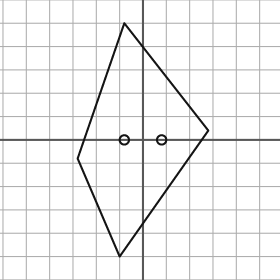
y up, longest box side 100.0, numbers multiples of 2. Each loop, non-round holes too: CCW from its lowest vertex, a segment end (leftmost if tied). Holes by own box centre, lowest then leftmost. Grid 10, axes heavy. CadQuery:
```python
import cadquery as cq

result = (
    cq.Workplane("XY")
    .moveTo(-10.0, -50.0)
    .lineTo(28.0, 4.0)
    .lineTo(-8.0, 50.0)
    .lineTo(-28.0, -8.0)
    .close()
    .moveTo(-8.0, 0.0)
    .circle(2.0)
    .moveTo(8.0, 0.0)
    .circle(2.0)
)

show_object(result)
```